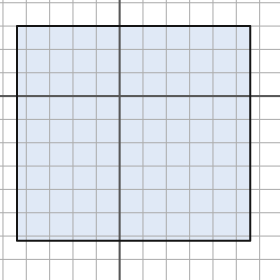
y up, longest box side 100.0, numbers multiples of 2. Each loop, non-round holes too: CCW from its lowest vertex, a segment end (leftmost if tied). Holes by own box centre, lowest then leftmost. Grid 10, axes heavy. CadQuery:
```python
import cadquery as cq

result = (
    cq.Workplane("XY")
    .moveTo(-44.0, -62.0)
    .lineTo(56.0, -62.0)
    .lineTo(56.0, 30.0)
    .lineTo(-44.0, 30.0)
    .close()
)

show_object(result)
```